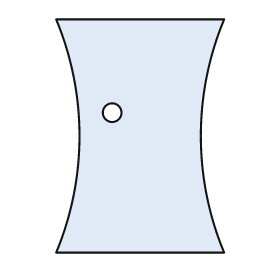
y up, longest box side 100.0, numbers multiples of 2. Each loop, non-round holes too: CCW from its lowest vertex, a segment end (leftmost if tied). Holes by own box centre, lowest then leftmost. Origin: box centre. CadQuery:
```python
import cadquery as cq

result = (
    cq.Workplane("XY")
    .moveTo(-36.0, -50.0)
    .lineTo(36.0, -50.0)
    .threePointArc((26.0, 0.0), (36.0, 50.0))
    .lineTo(-36.0, 50.0)
    .threePointArc((-26.0, 0.0), (-36.0, -50.0))
    .close()
    .moveTo(-12.0, 10.0)
    .circle(4.0)
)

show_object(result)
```